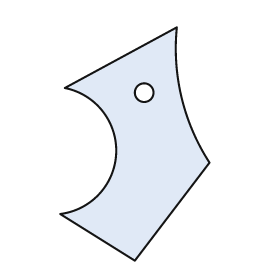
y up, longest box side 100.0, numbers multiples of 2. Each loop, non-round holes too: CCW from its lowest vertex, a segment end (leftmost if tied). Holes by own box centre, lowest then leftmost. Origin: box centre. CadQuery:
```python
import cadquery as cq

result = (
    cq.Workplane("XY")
    .moveTo(0.0, -50.0)
    .lineTo(32.0, -8.0)
    .threePointArc((20.0, 20.0), (18.0, 50.0))
    .lineTo(-30.0, 24.0)
    .threePointArc((-8.0, -4.0), (-32.0, -30.0))
    .close()
    .moveTo(4.0, 22.0)
    .circle(4.0)
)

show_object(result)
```